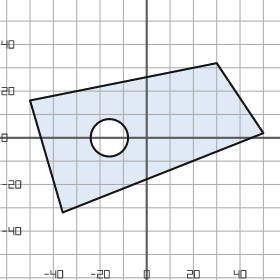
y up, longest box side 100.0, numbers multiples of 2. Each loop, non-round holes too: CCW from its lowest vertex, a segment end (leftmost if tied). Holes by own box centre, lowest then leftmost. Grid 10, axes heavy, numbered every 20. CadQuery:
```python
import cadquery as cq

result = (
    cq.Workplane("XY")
    .moveTo(-36.0, -32.0)
    .lineTo(50.0, 2.0)
    .lineTo(30.0, 32.0)
    .lineTo(-50.0, 16.0)
    .close()
    .moveTo(-16.0, 0.0)
    .circle(8.0)
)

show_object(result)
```